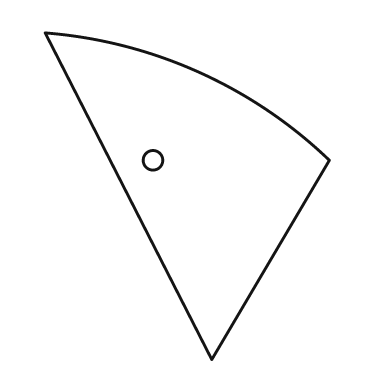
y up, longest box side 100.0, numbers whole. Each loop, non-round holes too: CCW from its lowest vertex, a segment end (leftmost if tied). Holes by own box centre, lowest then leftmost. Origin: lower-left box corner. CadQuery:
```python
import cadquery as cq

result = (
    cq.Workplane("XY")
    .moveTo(51.0, 0.0)
    .lineTo(87.0, 61.0)
    .threePointArc((47.0, 88.0), (0.0, 100.0))
    .close()
    .moveTo(33.0, 61.0)
    .circle(3.0)
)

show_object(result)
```